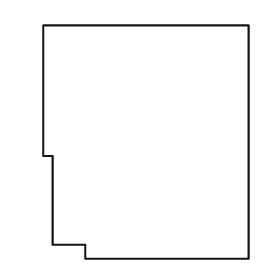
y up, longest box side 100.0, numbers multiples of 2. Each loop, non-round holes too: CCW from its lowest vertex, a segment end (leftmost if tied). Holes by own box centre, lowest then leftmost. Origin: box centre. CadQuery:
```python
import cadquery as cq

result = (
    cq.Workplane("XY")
    .moveTo(-26.0, -50.0)
    .lineTo(44.0, -50.0)
    .lineTo(44.0, 50.0)
    .lineTo(-44.0, 50.0)
    .lineTo(-44.0, -6.0)
    .lineTo(-40.0, -6.0)
    .lineTo(-40.0, -44.0)
    .lineTo(-26.0, -44.0)
    .close()
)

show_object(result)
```